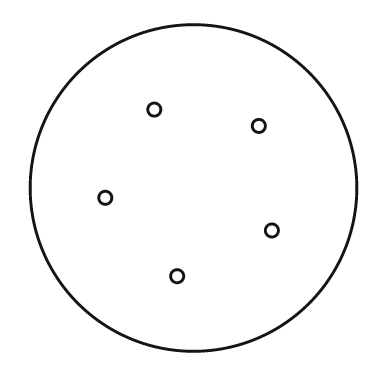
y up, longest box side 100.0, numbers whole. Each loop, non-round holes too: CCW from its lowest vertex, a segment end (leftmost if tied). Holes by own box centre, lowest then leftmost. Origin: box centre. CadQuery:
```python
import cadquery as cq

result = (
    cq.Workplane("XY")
    .moveTo(0.0, 0.0)
    .circle(50.0)
    .moveTo(-5.0, -27.0)
    .circle(2.0)
    .moveTo(24.0, -13.0)
    .circle(2.0)
    .moveTo(-27.0, -3.0)
    .circle(2.0)
    .moveTo(20.0, 19.0)
    .circle(2.0)
    .moveTo(-12.0, 24.0)
    .circle(2.0)
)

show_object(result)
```